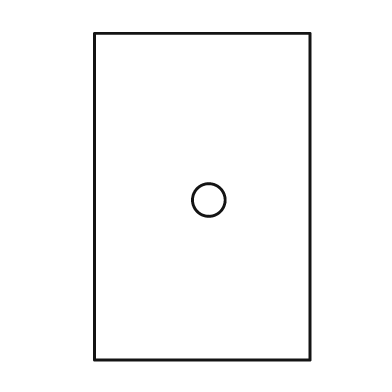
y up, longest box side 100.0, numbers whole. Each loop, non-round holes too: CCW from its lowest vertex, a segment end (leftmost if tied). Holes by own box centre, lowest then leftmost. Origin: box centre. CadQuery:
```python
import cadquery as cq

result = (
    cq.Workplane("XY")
    .moveTo(-33.0, -50.0)
    .lineTo(33.0, -50.0)
    .lineTo(33.0, 50.0)
    .lineTo(-33.0, 50.0)
    .close()
    .moveTo(2.0, -1.0)
    .circle(5.0)
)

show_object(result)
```